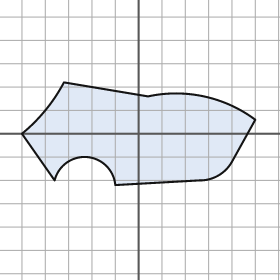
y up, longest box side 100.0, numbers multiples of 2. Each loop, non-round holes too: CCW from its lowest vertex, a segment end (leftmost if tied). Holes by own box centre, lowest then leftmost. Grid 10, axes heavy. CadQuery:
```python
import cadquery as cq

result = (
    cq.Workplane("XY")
    .moveTo(-10.0, -22.0)
    .lineTo(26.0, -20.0)
    .threePointArc((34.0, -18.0), (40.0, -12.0))
    .lineTo(50.0, 6.0)
    .threePointArc((28.0, 16.0), (4.0, 16.0))
    .lineTo(-32.0, 22.0)
    .threePointArc((-40.0, 10.0), (-50.0, 0.0))
    .lineTo(-36.0, -20.0)
    .threePointArc((-22.0, -10.0), (-10.0, -22.0))
    .close()
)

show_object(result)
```